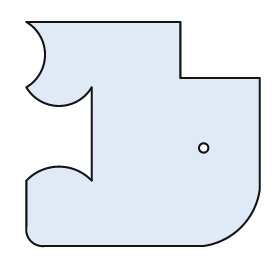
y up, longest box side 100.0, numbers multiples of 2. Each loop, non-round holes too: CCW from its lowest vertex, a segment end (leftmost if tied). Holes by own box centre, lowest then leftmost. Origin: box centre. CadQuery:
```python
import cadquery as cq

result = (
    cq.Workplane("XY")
    .moveTo(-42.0, -48.0)
    .lineTo(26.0, -48.0)
    .threePointArc((42.0, -40.0), (50.0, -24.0))
    .lineTo(50.0, 24.0)
    .lineTo(16.0, 24.0)
    .lineTo(16.0, 48.0)
    .lineTo(-50.0, 48.0)
    .threePointArc((-42.0, 34.0), (-50.0, 20.0))
    .threePointArc((-36.0, 12.0), (-22.0, 20.0))
    .lineTo(-22.0, -20.0)
    .threePointArc((-36.0, -14.0), (-50.0, -20.0))
    .lineTo(-50.0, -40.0)
    .threePointArc((-48.0, -46.0), (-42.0, -48.0))
    .close()
    .moveTo(26.0, -6.0)
    .circle(2.0)
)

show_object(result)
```